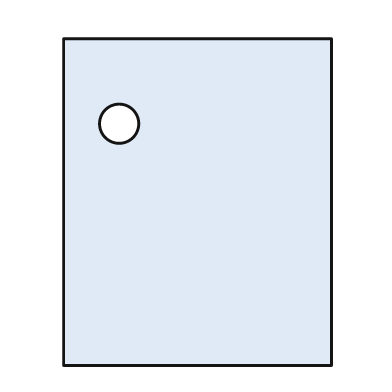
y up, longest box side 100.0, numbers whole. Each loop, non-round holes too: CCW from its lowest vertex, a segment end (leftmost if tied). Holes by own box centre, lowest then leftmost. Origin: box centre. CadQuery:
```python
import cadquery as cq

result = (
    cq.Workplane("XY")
    .moveTo(-41.0, -50.0)
    .lineTo(41.0, -50.0)
    .lineTo(41.0, 50.0)
    .lineTo(-41.0, 50.0)
    .close()
    .moveTo(-24.0, 24.0)
    .circle(6.0)
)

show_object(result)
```